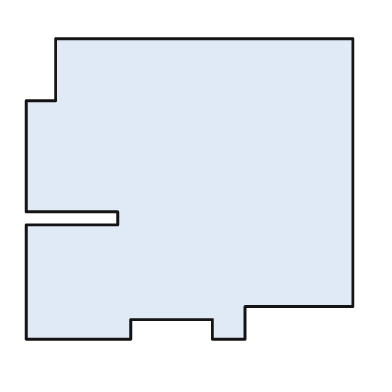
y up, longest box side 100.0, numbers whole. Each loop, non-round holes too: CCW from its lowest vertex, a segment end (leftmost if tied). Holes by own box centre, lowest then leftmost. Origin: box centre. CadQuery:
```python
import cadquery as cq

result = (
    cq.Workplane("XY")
    .moveTo(-50.0, -46.0)
    .lineTo(-18.0, -46.0)
    .lineTo(-18.0, -40.0)
    .lineTo(7.0, -40.0)
    .lineTo(7.0, -46.0)
    .lineTo(17.0, -46.0)
    .lineTo(17.0, -36.0)
    .lineTo(50.0, -36.0)
    .lineTo(50.0, 46.0)
    .lineTo(-41.0, 46.0)
    .lineTo(-41.0, 27.0)
    .lineTo(-50.0, 27.0)
    .lineTo(-50.0, -7.0)
    .lineTo(-22.0, -7.0)
    .lineTo(-22.0, -11.0)
    .lineTo(-50.0, -11.0)
    .close()
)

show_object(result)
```